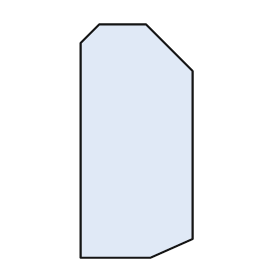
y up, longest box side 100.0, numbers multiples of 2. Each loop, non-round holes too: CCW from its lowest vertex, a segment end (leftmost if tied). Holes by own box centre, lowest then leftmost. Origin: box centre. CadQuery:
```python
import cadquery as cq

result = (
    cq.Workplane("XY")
    .moveTo(-24.0, -50.0)
    .lineTo(6.0, -50.0)
    .lineTo(24.0, -42.0)
    .lineTo(24.0, 30.0)
    .lineTo(4.0, 50.0)
    .lineTo(-16.0, 50.0)
    .lineTo(-24.0, 42.0)
    .close()
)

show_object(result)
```